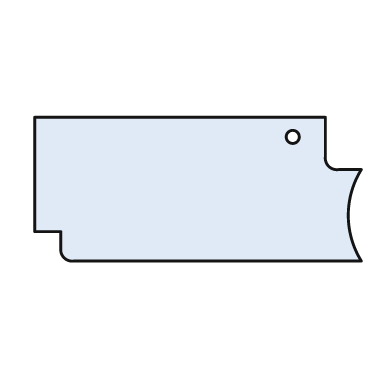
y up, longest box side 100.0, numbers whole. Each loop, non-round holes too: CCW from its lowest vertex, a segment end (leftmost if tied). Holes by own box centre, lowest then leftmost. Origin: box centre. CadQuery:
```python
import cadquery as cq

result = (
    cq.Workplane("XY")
    .moveTo(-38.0, -22.0)
    .lineTo(50.0, -22.0)
    .threePointArc((46.0, -8.0), (50.0, 6.0))
    .lineTo(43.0, 6.0)
    .threePointArc((40.0, 7.0), (39.0, 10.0))
    .lineTo(39.0, 22.0)
    .lineTo(-50.0, 22.0)
    .lineTo(-50.0, -13.0)
    .lineTo(-42.0, -13.0)
    .lineTo(-42.0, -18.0)
    .threePointArc((-41.0, -21.0), (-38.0, -22.0))
    .close()
    .moveTo(29.0, 16.0)
    .circle(2.0)
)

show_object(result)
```